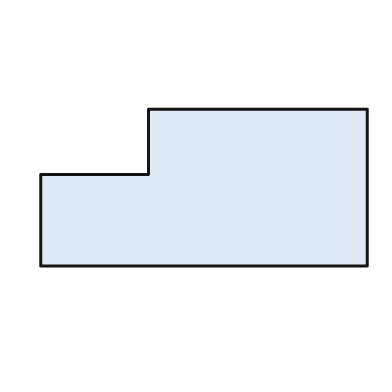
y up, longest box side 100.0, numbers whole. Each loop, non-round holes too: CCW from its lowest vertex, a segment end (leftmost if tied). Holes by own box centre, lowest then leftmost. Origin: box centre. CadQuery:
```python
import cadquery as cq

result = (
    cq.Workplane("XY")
    .moveTo(-50.0, -24.0)
    .lineTo(50.0, -24.0)
    .lineTo(50.0, 24.0)
    .lineTo(-17.0, 24.0)
    .lineTo(-17.0, 4.0)
    .lineTo(-50.0, 4.0)
    .close()
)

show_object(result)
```